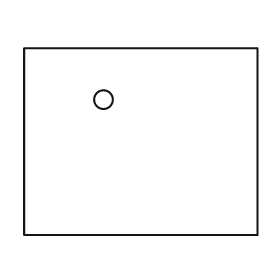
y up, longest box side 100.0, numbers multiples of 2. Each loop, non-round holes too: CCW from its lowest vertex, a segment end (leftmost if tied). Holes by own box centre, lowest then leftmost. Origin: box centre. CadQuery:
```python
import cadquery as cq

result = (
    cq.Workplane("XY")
    .moveTo(-50.0, -40.0)
    .lineTo(50.0, -40.0)
    .lineTo(50.0, 40.0)
    .lineTo(-50.0, 40.0)
    .close()
    .moveTo(-16.0, 18.0)
    .circle(4.0)
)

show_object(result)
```